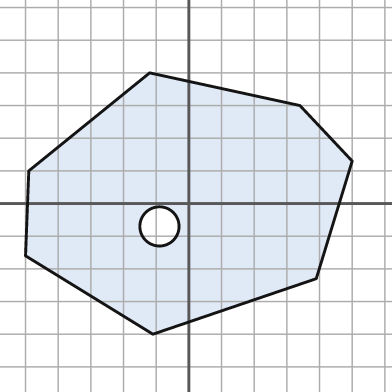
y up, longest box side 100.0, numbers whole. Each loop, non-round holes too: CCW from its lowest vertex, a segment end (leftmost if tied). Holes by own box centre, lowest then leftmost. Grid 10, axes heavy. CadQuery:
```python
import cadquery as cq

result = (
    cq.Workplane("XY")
    .moveTo(-11.0, -40.0)
    .lineTo(39.0, -23.0)
    .lineTo(50.0, 13.0)
    .lineTo(34.0, 30.0)
    .lineTo(-12.0, 40.0)
    .lineTo(-49.0, 10.0)
    .lineTo(-50.0, -16.0)
    .close()
    .moveTo(-9.0, -7.0)
    .circle(6.0)
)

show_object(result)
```